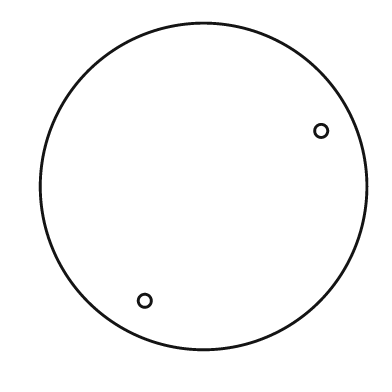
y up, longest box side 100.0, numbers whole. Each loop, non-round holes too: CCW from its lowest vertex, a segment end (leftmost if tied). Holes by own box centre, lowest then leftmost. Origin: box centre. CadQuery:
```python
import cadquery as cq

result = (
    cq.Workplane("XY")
    .moveTo(0.0, 0.0)
    .circle(50.0)
    .moveTo(-18.0, -35.0)
    .circle(2.0)
    .moveTo(36.0, 17.0)
    .circle(2.0)
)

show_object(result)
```